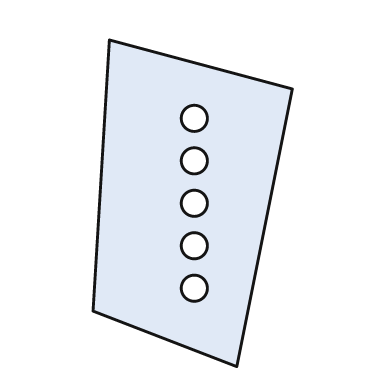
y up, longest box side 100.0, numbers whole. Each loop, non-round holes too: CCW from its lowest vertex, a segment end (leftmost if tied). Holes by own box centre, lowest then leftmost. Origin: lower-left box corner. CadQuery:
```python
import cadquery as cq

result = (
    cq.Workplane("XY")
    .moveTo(44.0, 0.0)
    .lineTo(61.0, 85.0)
    .lineTo(5.0, 100.0)
    .lineTo(0.0, 17.0)
    .close()
    .moveTo(31.0, 24.0)
    .circle(4.0)
    .moveTo(31.0, 37.0)
    .circle(4.0)
    .moveTo(31.0, 50.0)
    .circle(4.0)
    .moveTo(31.0, 63.0)
    .circle(4.0)
    .moveTo(31.0, 76.0)
    .circle(4.0)
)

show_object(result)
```